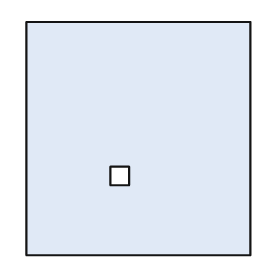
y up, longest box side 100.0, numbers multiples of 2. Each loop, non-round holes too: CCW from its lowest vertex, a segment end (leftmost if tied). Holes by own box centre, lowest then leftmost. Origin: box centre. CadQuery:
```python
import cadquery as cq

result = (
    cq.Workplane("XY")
    .moveTo(-48.0, -50.0)
    .lineTo(48.0, -50.0)
    .lineTo(48.0, 50.0)
    .lineTo(-48.0, 50.0)
    .close()
    .moveTo(-12.0, -20.0)
    .lineTo(-4.0, -20.0)
    .lineTo(-4.0, -12.0)
    .lineTo(-12.0, -12.0)
    .close()
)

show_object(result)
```